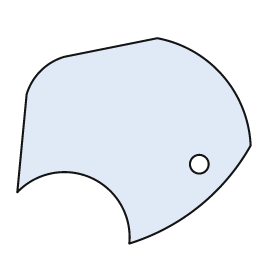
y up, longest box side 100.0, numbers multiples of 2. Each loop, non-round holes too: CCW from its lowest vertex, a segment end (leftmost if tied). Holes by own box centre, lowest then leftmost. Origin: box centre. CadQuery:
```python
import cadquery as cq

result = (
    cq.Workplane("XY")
    .moveTo(-2.0, -44.0)
    .threePointArc((28.0, -28.0), (50.0, -2.0))
    .threePointArc((38.0, 28.0), (10.0, 44.0))
    .lineTo(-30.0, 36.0)
    .threePointArc((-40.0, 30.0), (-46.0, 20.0))
    .lineTo(-50.0, -22.0)
    .threePointArc((-18.0, -16.0), (-2.0, -44.0))
    .close()
    .moveTo(28.0, -10.0)
    .circle(4.0)
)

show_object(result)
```